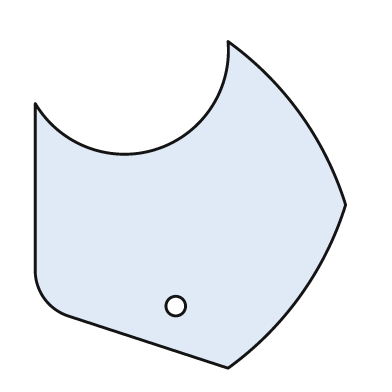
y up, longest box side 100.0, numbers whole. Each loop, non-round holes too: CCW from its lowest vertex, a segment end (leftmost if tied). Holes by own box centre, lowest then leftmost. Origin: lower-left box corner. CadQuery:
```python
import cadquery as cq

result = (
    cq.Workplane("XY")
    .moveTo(59.0, 0.0)
    .threePointArc((81.0, 22.0), (95.0, 50.0))
    .threePointArc((81.0, 78.0), (59.0, 100.0))
    .threePointArc((37.0, 67.0), (0.0, 81.0))
    .lineTo(0.0, 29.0)
    .threePointArc((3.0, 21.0), (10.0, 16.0))
    .close()
    .moveTo(43.0, 19.0)
    .circle(3.0)
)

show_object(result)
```